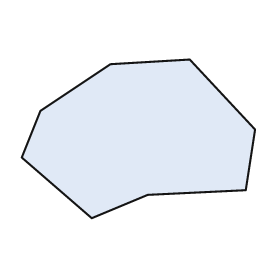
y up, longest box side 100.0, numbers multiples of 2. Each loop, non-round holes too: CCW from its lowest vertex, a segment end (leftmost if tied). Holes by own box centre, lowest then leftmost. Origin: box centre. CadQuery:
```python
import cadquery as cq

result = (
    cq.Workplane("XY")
    .moveTo(-20.0, -34.0)
    .lineTo(4.0, -24.0)
    .lineTo(46.0, -22.0)
    .lineTo(50.0, 4.0)
    .lineTo(22.0, 34.0)
    .lineTo(-12.0, 32.0)
    .lineTo(-42.0, 12.0)
    .lineTo(-50.0, -8.0)
    .close()
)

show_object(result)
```